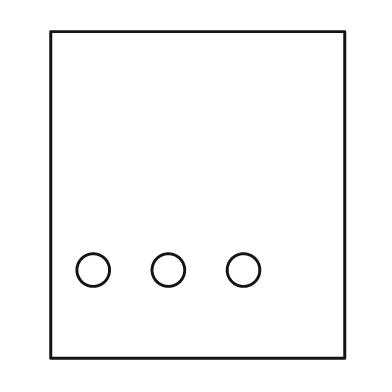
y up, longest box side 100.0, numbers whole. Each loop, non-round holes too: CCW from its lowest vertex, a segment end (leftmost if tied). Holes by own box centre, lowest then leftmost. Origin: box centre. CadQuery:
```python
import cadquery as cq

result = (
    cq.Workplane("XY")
    .moveTo(-45.0, -50.0)
    .lineTo(45.0, -50.0)
    .lineTo(45.0, 50.0)
    .lineTo(-45.0, 50.0)
    .close()
    .moveTo(-32.0, -23.0)
    .circle(5.0)
    .moveTo(-9.0, -23.0)
    .circle(5.0)
    .moveTo(14.0, -23.0)
    .circle(5.0)
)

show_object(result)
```